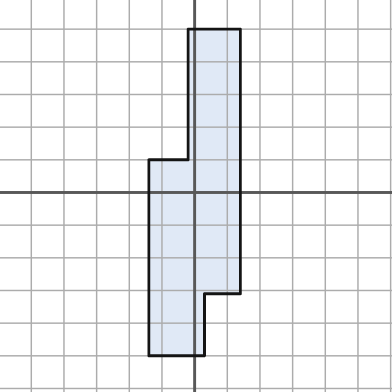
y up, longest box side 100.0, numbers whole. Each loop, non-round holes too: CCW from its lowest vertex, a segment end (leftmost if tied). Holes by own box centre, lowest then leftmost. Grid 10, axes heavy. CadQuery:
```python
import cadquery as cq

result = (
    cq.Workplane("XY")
    .moveTo(-14.0, -50.0)
    .lineTo(3.0, -50.0)
    .lineTo(3.0, -31.0)
    .lineTo(14.0, -31.0)
    .lineTo(14.0, 50.0)
    .lineTo(-2.0, 50.0)
    .lineTo(-2.0, 10.0)
    .lineTo(-14.0, 10.0)
    .close()
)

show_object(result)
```